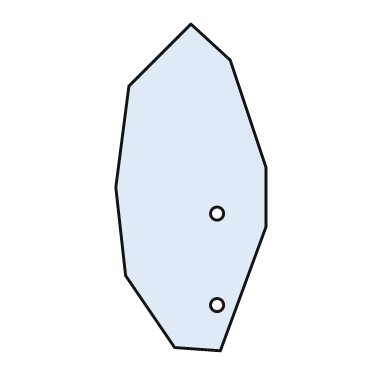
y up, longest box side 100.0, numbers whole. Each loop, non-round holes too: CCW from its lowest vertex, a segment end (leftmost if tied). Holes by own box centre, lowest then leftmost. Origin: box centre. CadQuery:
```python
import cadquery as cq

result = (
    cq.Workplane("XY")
    .moveTo(9.0, -50.0)
    .lineTo(23.0, -12.0)
    .lineTo(23.0, 6.0)
    .lineTo(12.0, 39.0)
    .lineTo(0.0, 50.0)
    .lineTo(-19.0, 31.0)
    .lineTo(-23.0, 0.0)
    .lineTo(-20.0, -27.0)
    .lineTo(-5.0, -49.0)
    .close()
    .moveTo(8.0, -36.0)
    .circle(2.0)
    .moveTo(8.0, -8.0)
    .circle(2.0)
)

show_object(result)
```